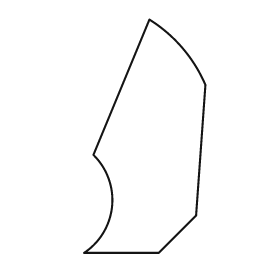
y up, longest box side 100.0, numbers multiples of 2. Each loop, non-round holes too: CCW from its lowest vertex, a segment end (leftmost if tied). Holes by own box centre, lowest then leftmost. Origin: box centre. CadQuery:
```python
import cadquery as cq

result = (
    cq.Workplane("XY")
    .moveTo(-26.0, -50.0)
    .lineTo(6.0, -50.0)
    .lineTo(22.0, -34.0)
    .lineTo(26.0, 22.0)
    .threePointArc((16.0, 38.0), (2.0, 50.0))
    .lineTo(-22.0, -8.0)
    .threePointArc((-14.0, -30.0), (-26.0, -50.0))
    .close()
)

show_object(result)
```